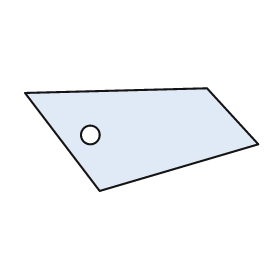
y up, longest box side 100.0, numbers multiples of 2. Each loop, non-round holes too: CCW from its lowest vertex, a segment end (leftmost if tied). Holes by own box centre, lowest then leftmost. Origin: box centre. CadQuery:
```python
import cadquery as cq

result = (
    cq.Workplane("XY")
    .moveTo(-18.0, -22.0)
    .lineTo(50.0, -2.0)
    .lineTo(28.0, 22.0)
    .lineTo(-50.0, 20.0)
    .close()
    .moveTo(-22.0, 2.0)
    .circle(4.0)
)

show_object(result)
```